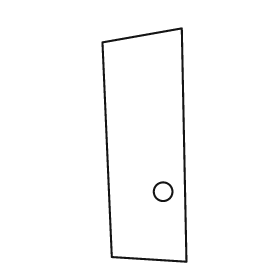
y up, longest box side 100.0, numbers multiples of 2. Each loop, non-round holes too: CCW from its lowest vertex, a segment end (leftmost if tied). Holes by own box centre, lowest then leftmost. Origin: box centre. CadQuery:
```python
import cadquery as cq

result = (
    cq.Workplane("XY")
    .moveTo(18.0, -50.0)
    .lineTo(16.0, 50.0)
    .lineTo(-18.0, 44.0)
    .lineTo(-14.0, -48.0)
    .close()
    .moveTo(8.0, -20.0)
    .circle(4.0)
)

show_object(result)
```